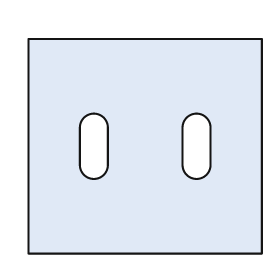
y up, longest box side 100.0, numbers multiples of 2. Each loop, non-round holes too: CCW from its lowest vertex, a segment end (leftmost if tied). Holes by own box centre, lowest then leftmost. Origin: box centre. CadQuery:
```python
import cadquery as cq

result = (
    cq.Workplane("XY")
    .moveTo(-50.0, -46.0)
    .lineTo(50.0, -46.0)
    .lineTo(50.0, 46.0)
    .lineTo(-50.0, 46.0)
    .close()
    .moveTo(-28.0, -8.0)
    .threePointArc((-22.0, -14.0), (-16.0, -8.0))
    .lineTo(-16.0, 8.0)
    .threePointArc((-22.0, 14.0), (-28.0, 8.0))
    .close()
    .moveTo(16.0, -8.0)
    .threePointArc((22.0, -14.0), (28.0, -8.0))
    .lineTo(28.0, 8.0)
    .threePointArc((22.0, 14.0), (16.0, 8.0))
    .close()
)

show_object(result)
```